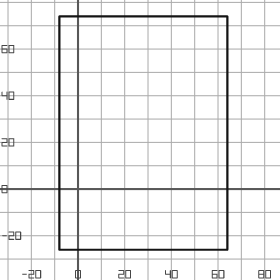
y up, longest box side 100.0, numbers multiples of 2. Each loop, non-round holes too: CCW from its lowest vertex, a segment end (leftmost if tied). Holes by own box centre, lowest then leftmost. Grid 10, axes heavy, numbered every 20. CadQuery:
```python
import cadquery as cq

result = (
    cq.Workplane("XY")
    .moveTo(-8.0, -26.0)
    .lineTo(64.0, -26.0)
    .lineTo(64.0, 74.0)
    .lineTo(-8.0, 74.0)
    .close()
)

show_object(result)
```